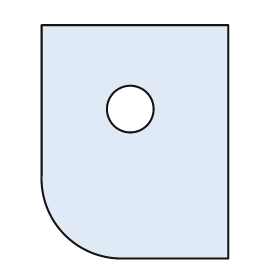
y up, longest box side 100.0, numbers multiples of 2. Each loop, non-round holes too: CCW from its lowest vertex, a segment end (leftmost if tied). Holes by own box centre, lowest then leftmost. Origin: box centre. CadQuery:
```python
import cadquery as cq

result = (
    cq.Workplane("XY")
    .moveTo(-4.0, -50.0)
    .lineTo(40.0, -50.0)
    .lineTo(40.0, 50.0)
    .lineTo(-40.0, 50.0)
    .lineTo(-40.0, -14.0)
    .threePointArc((-30.0, -40.0), (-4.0, -50.0))
    .close()
    .moveTo(-2.0, 14.0)
    .circle(10.0)
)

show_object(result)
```